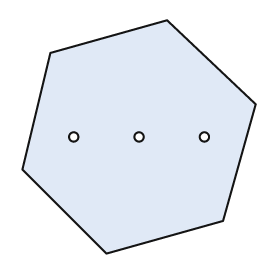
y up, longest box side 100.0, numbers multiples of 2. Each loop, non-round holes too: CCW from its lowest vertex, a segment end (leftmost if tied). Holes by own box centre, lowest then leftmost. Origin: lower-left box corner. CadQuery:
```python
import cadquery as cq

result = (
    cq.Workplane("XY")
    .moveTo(36.0, 0.0)
    .lineTo(86.0, 14.0)
    .lineTo(100.0, 64.0)
    .lineTo(62.0, 100.0)
    .lineTo(12.0, 86.0)
    .lineTo(0.0, 36.0)
    .close()
    .moveTo(22.0, 50.0)
    .circle(2.0)
    .moveTo(50.0, 50.0)
    .circle(2.0)
    .moveTo(78.0, 50.0)
    .circle(2.0)
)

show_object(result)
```